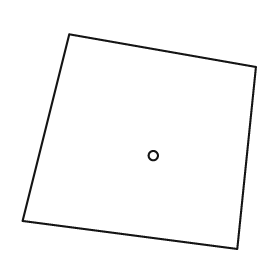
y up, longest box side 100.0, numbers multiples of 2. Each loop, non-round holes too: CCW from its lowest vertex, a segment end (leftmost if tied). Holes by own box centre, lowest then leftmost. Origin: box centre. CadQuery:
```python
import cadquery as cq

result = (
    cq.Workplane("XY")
    .moveTo(42.0, -46.0)
    .lineTo(50.0, 32.0)
    .lineTo(-30.0, 46.0)
    .lineTo(-50.0, -34.0)
    .close()
    .moveTo(6.0, -6.0)
    .circle(2.0)
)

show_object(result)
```